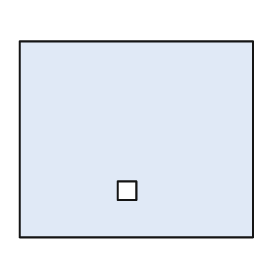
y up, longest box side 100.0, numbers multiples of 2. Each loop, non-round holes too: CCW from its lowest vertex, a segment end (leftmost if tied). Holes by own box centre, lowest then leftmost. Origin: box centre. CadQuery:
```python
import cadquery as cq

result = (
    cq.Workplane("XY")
    .moveTo(-50.0, -42.0)
    .lineTo(50.0, -42.0)
    .lineTo(50.0, 42.0)
    .lineTo(-50.0, 42.0)
    .close()
    .moveTo(-8.0, -26.0)
    .lineTo(0.0, -26.0)
    .lineTo(0.0, -18.0)
    .lineTo(-8.0, -18.0)
    .close()
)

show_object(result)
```